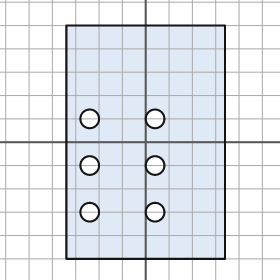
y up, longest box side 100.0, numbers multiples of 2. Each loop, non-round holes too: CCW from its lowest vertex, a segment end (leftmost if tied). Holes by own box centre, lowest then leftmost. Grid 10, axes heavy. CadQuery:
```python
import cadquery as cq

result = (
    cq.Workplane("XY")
    .moveTo(-34.0, -50.0)
    .lineTo(34.0, -50.0)
    .lineTo(34.0, 50.0)
    .lineTo(-34.0, 50.0)
    .close()
    .moveTo(-24.0, -30.0)
    .circle(4.0)
    .moveTo(4.0, -30.0)
    .circle(4.0)
    .moveTo(-24.0, -10.0)
    .circle(4.0)
    .moveTo(4.0, -10.0)
    .circle(4.0)
    .moveTo(-24.0, 10.0)
    .circle(4.0)
    .moveTo(4.0, 10.0)
    .circle(4.0)
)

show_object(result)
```